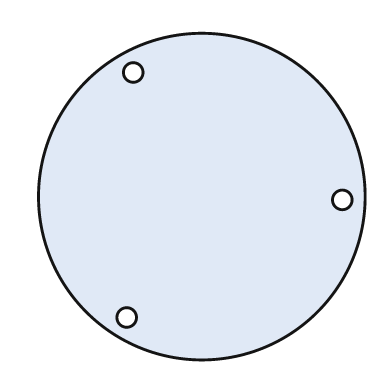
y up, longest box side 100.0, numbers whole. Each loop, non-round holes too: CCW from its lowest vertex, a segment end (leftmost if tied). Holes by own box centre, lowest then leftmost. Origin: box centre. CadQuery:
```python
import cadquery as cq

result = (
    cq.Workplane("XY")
    .moveTo(0.0, 0.0)
    .circle(50.0)
    .moveTo(-23.0, -37.0)
    .circle(3.0)
    .moveTo(43.0, -1.0)
    .circle(3.0)
    .moveTo(-21.0, 38.0)
    .circle(3.0)
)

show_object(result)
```